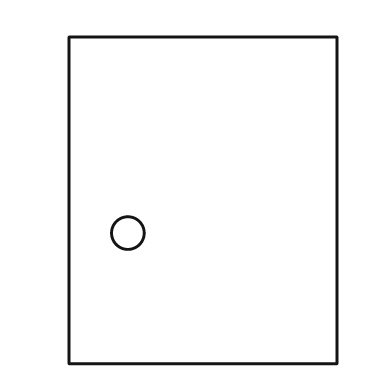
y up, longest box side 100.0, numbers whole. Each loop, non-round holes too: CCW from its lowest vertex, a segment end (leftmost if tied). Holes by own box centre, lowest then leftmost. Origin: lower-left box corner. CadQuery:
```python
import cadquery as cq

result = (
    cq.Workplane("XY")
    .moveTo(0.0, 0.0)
    .lineTo(82.0, 0.0)
    .lineTo(82.0, 100.0)
    .lineTo(0.0, 100.0)
    .close()
    .moveTo(18.0, 40.0)
    .circle(5.0)
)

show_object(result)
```